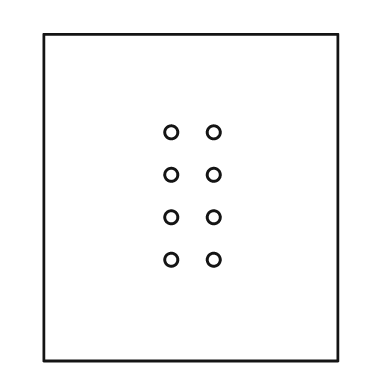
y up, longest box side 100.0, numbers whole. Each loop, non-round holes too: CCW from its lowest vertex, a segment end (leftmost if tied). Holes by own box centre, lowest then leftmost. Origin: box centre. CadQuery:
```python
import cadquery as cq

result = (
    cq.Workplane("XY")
    .moveTo(-45.0, -50.0)
    .lineTo(45.0, -50.0)
    .lineTo(45.0, 50.0)
    .lineTo(-45.0, 50.0)
    .close()
    .moveTo(-6.0, -19.0)
    .circle(2.0)
    .moveTo(7.0, -19.0)
    .circle(2.0)
    .moveTo(-6.0, -6.0)
    .circle(2.0)
    .moveTo(7.0, -6.0)
    .circle(2.0)
    .moveTo(-6.0, 7.0)
    .circle(2.0)
    .moveTo(7.0, 7.0)
    .circle(2.0)
    .moveTo(-6.0, 20.0)
    .circle(2.0)
    .moveTo(7.0, 20.0)
    .circle(2.0)
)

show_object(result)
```